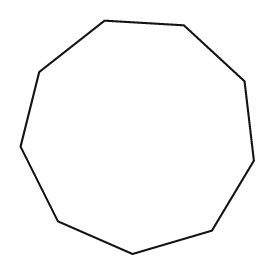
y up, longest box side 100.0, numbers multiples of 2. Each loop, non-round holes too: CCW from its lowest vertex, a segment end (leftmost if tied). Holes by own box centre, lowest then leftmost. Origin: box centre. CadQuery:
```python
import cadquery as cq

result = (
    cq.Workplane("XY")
    .moveTo(-2.0, -50.0)
    .lineTo(32.0, -40.0)
    .lineTo(50.0, -10.0)
    .lineTo(46.0, 24.0)
    .lineTo(20.0, 48.0)
    .lineTo(-14.0, 50.0)
    .lineTo(-42.0, 28.0)
    .lineTo(-50.0, -4.0)
    .lineTo(-34.0, -36.0)
    .close()
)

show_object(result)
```